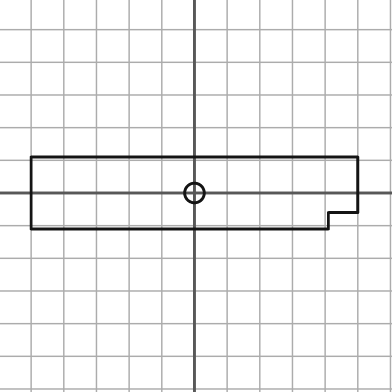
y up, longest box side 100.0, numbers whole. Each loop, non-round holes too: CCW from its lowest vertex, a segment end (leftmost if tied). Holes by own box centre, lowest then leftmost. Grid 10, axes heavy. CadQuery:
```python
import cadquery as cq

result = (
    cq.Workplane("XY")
    .moveTo(-50.0, -11.0)
    .lineTo(41.0, -11.0)
    .lineTo(41.0, -6.0)
    .lineTo(50.0, -6.0)
    .lineTo(50.0, 11.0)
    .lineTo(-50.0, 11.0)
    .close()
    .moveTo(0.0, 0.0)
    .circle(3.0)
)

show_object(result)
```